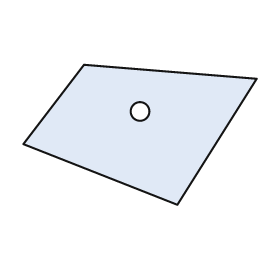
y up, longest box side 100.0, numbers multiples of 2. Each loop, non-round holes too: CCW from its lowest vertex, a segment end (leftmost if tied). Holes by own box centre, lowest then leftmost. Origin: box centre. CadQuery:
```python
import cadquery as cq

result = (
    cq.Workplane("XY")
    .moveTo(16.0, -30.0)
    .lineTo(50.0, 24.0)
    .lineTo(-24.0, 30.0)
    .lineTo(-50.0, -4.0)
    .close()
    .moveTo(0.0, 10.0)
    .circle(4.0)
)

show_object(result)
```